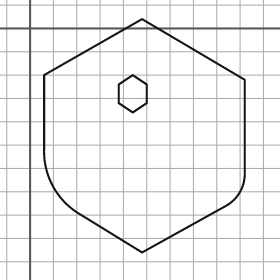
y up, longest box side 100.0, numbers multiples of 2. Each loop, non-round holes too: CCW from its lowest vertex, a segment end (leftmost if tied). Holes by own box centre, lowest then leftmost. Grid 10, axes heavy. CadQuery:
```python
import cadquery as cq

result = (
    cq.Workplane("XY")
    .moveTo(48.0, -96.0)
    .lineTo(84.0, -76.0)
    .threePointArc((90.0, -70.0), (92.0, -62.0))
    .lineTo(92.0, -22.0)
    .lineTo(48.0, 4.0)
    .lineTo(6.0, -20.0)
    .lineTo(6.0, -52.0)
    .threePointArc((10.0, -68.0), (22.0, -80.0))
    .close()
    .moveTo(44.0, -36.0)
    .lineTo(50.0, -32.0)
    .lineTo(50.0, -24.0)
    .lineTo(44.0, -20.0)
    .lineTo(38.0, -24.0)
    .lineTo(38.0, -32.0)
    .close()
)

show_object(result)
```